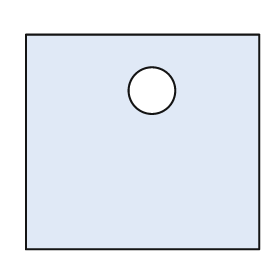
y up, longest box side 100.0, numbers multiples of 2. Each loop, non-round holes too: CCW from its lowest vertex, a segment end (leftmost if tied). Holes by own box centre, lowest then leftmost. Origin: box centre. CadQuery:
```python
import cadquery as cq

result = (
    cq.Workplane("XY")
    .moveTo(-50.0, -46.0)
    .lineTo(50.0, -46.0)
    .lineTo(50.0, 46.0)
    .lineTo(-50.0, 46.0)
    .close()
    .moveTo(4.0, 22.0)
    .circle(10.0)
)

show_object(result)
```